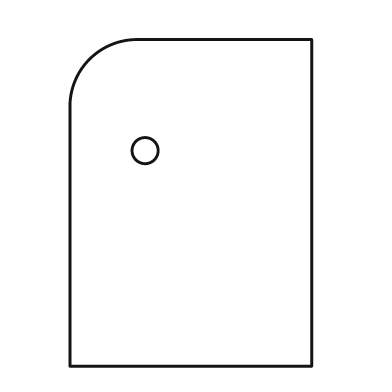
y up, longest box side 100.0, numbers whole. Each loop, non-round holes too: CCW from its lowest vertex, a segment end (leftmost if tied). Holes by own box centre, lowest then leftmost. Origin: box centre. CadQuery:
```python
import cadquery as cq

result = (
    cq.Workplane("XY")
    .moveTo(-37.0, -50.0)
    .lineTo(37.0, -50.0)
    .lineTo(37.0, 50.0)
    .lineTo(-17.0, 50.0)
    .threePointArc((-31.0, 44.0), (-37.0, 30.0))
    .close()
    .moveTo(-14.0, 16.0)
    .circle(4.0)
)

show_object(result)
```